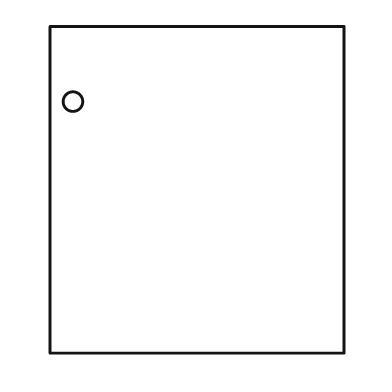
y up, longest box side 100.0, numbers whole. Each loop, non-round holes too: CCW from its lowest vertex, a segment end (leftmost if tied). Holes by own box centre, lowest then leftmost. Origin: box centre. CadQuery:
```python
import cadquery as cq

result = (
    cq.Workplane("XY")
    .moveTo(-45.0, -50.0)
    .lineTo(45.0, -50.0)
    .lineTo(45.0, 50.0)
    .lineTo(-45.0, 50.0)
    .close()
    .moveTo(-38.0, 27.0)
    .circle(3.0)
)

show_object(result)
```